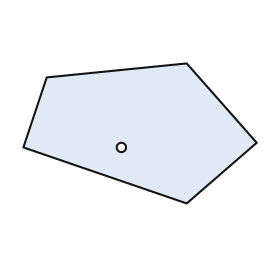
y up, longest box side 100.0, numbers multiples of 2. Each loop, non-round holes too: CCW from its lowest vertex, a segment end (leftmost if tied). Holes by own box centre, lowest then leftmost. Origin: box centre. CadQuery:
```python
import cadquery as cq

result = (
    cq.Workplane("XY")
    .moveTo(20.0, -30.0)
    .lineTo(50.0, -4.0)
    .lineTo(20.0, 30.0)
    .lineTo(-40.0, 24.0)
    .lineTo(-50.0, -6.0)
    .close()
    .moveTo(-8.0, -6.0)
    .circle(2.0)
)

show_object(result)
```